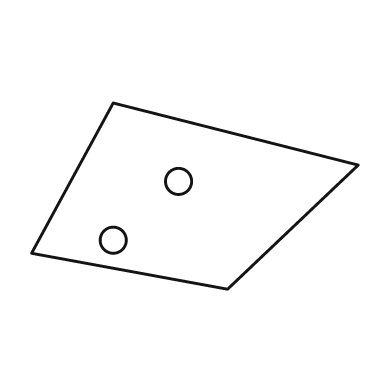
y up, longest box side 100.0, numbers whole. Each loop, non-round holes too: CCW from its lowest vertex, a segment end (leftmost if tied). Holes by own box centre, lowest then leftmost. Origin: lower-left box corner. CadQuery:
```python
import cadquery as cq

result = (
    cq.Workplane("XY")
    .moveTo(60.0, 0.0)
    .lineTo(100.0, 38.0)
    .lineTo(25.0, 57.0)
    .lineTo(0.0, 11.0)
    .close()
    .moveTo(25.0, 15.0)
    .circle(4.0)
    .moveTo(45.0, 33.0)
    .circle(4.0)
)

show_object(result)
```